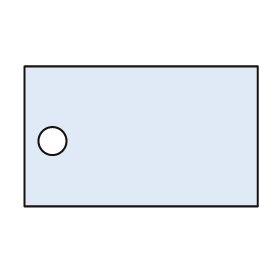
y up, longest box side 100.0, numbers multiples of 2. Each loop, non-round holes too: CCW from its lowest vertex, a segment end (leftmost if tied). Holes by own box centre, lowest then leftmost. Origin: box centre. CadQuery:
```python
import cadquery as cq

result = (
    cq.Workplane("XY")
    .moveTo(-50.0, -30.0)
    .lineTo(50.0, -30.0)
    .lineTo(50.0, 30.0)
    .lineTo(-50.0, 30.0)
    .close()
    .moveTo(-38.0, -2.0)
    .circle(6.0)
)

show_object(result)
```